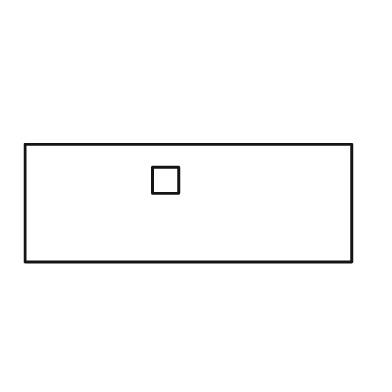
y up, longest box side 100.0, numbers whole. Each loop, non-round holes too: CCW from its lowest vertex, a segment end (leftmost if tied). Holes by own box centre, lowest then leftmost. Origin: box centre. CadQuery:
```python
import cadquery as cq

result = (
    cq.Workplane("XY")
    .moveTo(-50.0, -18.0)
    .lineTo(50.0, -18.0)
    .lineTo(50.0, 18.0)
    .lineTo(-50.0, 18.0)
    .close()
    .moveTo(-11.0, 3.0)
    .lineTo(-3.0, 3.0)
    .lineTo(-3.0, 11.0)
    .lineTo(-11.0, 11.0)
    .close()
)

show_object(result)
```